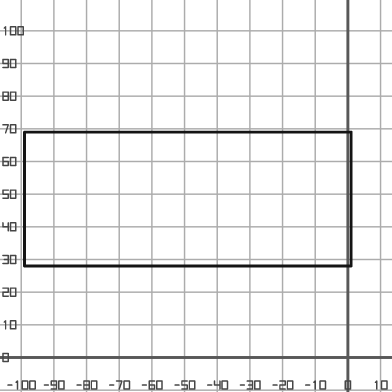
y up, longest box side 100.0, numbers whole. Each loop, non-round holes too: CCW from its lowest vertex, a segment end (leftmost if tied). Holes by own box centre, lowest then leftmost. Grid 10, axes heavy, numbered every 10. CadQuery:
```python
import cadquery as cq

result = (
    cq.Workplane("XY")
    .moveTo(-99.0, 28.0)
    .lineTo(1.0, 28.0)
    .lineTo(1.0, 69.0)
    .lineTo(-99.0, 69.0)
    .close()
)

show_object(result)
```